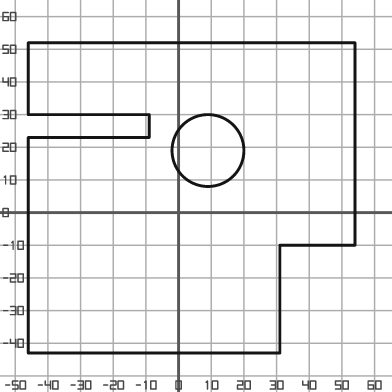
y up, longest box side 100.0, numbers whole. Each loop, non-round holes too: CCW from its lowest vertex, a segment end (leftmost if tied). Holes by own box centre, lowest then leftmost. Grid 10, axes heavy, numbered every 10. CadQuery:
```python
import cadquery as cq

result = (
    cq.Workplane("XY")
    .moveTo(-46.0, -43.0)
    .lineTo(31.0, -43.0)
    .lineTo(31.0, -10.0)
    .lineTo(54.0, -10.0)
    .lineTo(54.0, 52.0)
    .lineTo(-46.0, 52.0)
    .lineTo(-46.0, 30.0)
    .lineTo(-9.0, 30.0)
    .lineTo(-9.0, 23.0)
    .lineTo(-46.0, 23.0)
    .close()
    .moveTo(9.0, 19.0)
    .circle(11.0)
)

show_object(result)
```